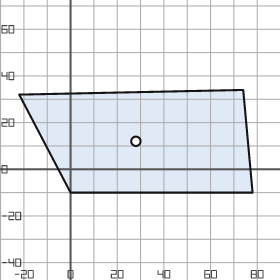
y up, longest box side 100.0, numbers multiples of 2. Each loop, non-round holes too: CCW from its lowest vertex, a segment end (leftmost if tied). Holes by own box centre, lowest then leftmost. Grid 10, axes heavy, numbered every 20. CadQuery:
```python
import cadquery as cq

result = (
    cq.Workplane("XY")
    .moveTo(0.0, -10.0)
    .lineTo(78.0, -10.0)
    .lineTo(74.0, 34.0)
    .lineTo(-22.0, 32.0)
    .close()
    .moveTo(28.0, 12.0)
    .circle(2.0)
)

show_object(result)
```